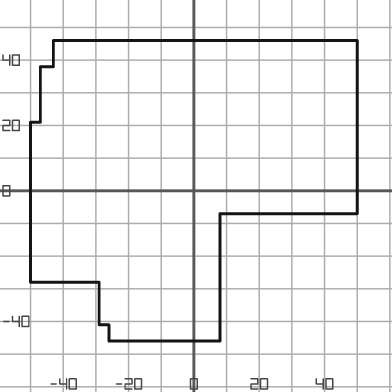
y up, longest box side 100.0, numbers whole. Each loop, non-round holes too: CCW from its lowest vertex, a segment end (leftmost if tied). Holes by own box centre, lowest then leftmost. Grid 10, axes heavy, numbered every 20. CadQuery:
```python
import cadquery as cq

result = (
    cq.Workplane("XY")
    .moveTo(-26.0, -46.0)
    .lineTo(8.0, -46.0)
    .lineTo(8.0, -7.0)
    .lineTo(50.0, -7.0)
    .lineTo(50.0, 46.0)
    .lineTo(-43.0, 46.0)
    .lineTo(-43.0, 38.0)
    .lineTo(-47.0, 38.0)
    .lineTo(-47.0, 21.0)
    .lineTo(-50.0, 21.0)
    .lineTo(-50.0, -28.0)
    .lineTo(-29.0, -28.0)
    .lineTo(-29.0, -41.0)
    .lineTo(-26.0, -41.0)
    .close()
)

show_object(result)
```